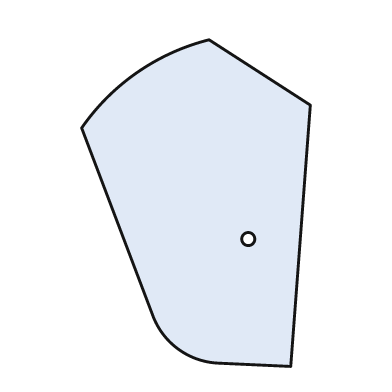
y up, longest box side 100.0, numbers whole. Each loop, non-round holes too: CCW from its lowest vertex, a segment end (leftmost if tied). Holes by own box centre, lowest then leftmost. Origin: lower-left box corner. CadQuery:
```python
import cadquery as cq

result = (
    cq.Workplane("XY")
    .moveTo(64.0, 0.0)
    .lineTo(70.0, 80.0)
    .lineTo(39.0, 100.0)
    .threePointArc((17.0, 90.0), (0.0, 73.0))
    .lineTo(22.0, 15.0)
    .threePointArc((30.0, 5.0), (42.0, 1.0))
    .close()
    .moveTo(51.0, 39.0)
    .circle(2.0)
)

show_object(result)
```